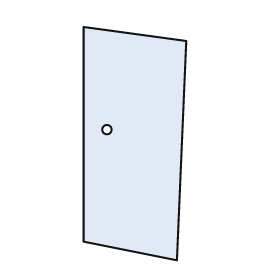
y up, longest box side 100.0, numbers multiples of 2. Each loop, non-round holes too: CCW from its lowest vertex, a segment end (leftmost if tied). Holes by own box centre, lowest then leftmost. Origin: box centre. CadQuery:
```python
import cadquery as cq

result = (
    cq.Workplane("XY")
    .moveTo(18.0, -50.0)
    .lineTo(22.0, 44.0)
    .lineTo(-22.0, 50.0)
    .lineTo(-22.0, -42.0)
    .close()
    .moveTo(-12.0, 6.0)
    .circle(2.0)
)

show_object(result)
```